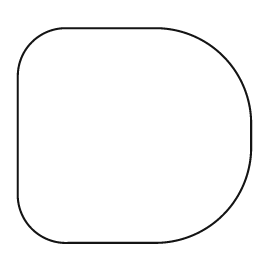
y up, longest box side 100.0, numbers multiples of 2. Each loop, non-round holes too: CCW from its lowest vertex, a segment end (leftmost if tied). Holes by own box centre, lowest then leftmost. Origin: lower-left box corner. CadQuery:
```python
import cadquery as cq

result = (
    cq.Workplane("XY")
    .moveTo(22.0, 0.0)
    .lineTo(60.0, 0.0)
    .threePointArc((88.0, 12.0), (100.0, 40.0))
    .lineTo(100.0, 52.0)
    .threePointArc((88.0, 80.0), (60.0, 92.0))
    .lineTo(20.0, 92.0)
    .threePointArc((6.0, 86.0), (0.0, 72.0))
    .lineTo(0.0, 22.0)
    .threePointArc((6.0, 6.0), (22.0, 0.0))
    .close()
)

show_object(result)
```